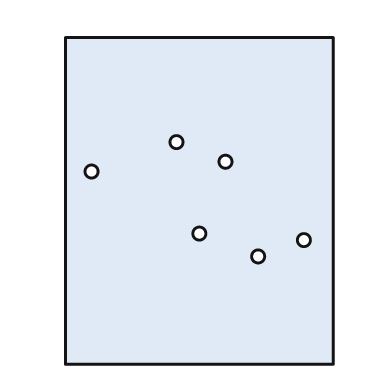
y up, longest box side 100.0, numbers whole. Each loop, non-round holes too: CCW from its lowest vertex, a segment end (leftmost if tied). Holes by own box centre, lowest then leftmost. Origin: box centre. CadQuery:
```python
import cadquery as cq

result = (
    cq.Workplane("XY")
    .moveTo(-41.0, -50.0)
    .lineTo(41.0, -50.0)
    .lineTo(41.0, 50.0)
    .lineTo(-41.0, 50.0)
    .close()
    .moveTo(18.0, -17.0)
    .circle(2.0)
    .moveTo(32.0, -12.0)
    .circle(2.0)
    .moveTo(0.0, -10.0)
    .circle(2.0)
    .moveTo(-33.0, 9.0)
    .circle(2.0)
    .moveTo(8.0, 12.0)
    .circle(2.0)
    .moveTo(-7.0, 18.0)
    .circle(2.0)
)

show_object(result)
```